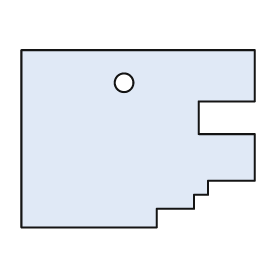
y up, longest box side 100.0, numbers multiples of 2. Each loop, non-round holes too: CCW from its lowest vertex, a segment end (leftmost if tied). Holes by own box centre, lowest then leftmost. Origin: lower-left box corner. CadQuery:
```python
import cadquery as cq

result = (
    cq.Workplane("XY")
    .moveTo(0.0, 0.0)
    .lineTo(58.0, 0.0)
    .lineTo(58.0, 8.0)
    .lineTo(74.0, 8.0)
    .lineTo(74.0, 14.0)
    .lineTo(80.0, 14.0)
    .lineTo(80.0, 20.0)
    .lineTo(100.0, 20.0)
    .lineTo(100.0, 40.0)
    .lineTo(76.0, 40.0)
    .lineTo(76.0, 54.0)
    .lineTo(100.0, 54.0)
    .lineTo(100.0, 76.0)
    .lineTo(0.0, 76.0)
    .close()
    .moveTo(44.0, 62.0)
    .circle(4.0)
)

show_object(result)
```